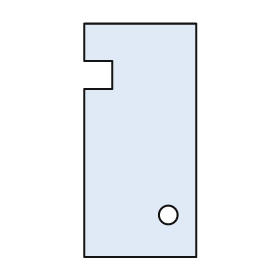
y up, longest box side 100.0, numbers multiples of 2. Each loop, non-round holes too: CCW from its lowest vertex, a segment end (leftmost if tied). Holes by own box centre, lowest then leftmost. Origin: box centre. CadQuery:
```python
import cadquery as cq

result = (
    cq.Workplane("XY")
    .moveTo(-24.0, -50.0)
    .lineTo(24.0, -50.0)
    .lineTo(24.0, 50.0)
    .lineTo(-24.0, 50.0)
    .lineTo(-24.0, 34.0)
    .lineTo(-12.0, 34.0)
    .lineTo(-12.0, 22.0)
    .lineTo(-24.0, 22.0)
    .close()
    .moveTo(12.0, -32.0)
    .circle(4.0)
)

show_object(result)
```